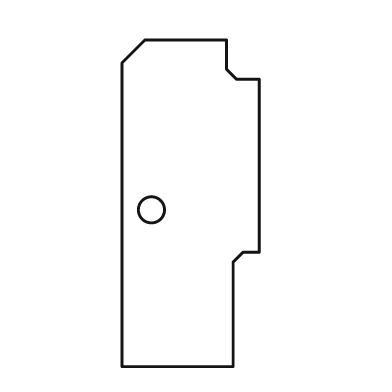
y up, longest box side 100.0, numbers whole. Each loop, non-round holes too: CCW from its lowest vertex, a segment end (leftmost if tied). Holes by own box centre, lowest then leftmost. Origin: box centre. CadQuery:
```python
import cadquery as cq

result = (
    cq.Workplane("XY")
    .moveTo(-21.0, -50.0)
    .lineTo(13.0, -50.0)
    .lineTo(13.0, -18.0)
    .lineTo(16.0, -15.0)
    .lineTo(21.0, -15.0)
    .lineTo(21.0, 38.0)
    .lineTo(14.0, 38.0)
    .lineTo(11.0, 41.0)
    .lineTo(11.0, 50.0)
    .lineTo(-14.0, 50.0)
    .lineTo(-21.0, 43.0)
    .close()
    .moveTo(-12.0, -2.0)
    .circle(4.0)
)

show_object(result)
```